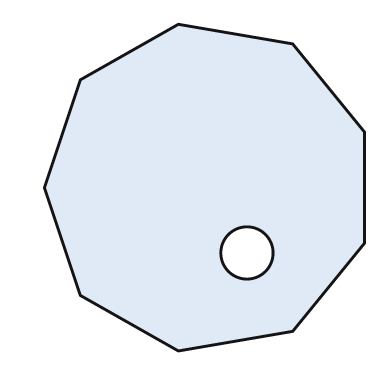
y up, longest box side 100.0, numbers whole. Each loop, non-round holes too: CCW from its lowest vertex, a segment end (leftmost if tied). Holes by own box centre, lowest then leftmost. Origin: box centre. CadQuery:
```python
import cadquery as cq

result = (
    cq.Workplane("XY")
    .moveTo(-8.0, -50.0)
    .lineTo(27.0, -44.0)
    .lineTo(49.0, -17.0)
    .lineTo(49.0, 17.0)
    .lineTo(27.0, 44.0)
    .lineTo(-8.0, 50.0)
    .lineTo(-38.0, 33.0)
    .lineTo(-49.0, 0.0)
    .lineTo(-38.0, -33.0)
    .close()
    .moveTo(13.0, -20.0)
    .circle(8.0)
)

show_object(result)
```